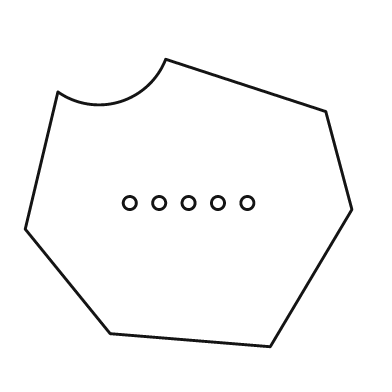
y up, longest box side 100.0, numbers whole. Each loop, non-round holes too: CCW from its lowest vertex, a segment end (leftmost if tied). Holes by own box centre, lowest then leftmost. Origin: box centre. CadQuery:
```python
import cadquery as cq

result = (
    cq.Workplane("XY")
    .moveTo(25.0, -44.0)
    .lineTo(50.0, -2.0)
    .lineTo(42.0, 28.0)
    .lineTo(-7.0, 44.0)
    .threePointArc((-21.0, 31.0), (-40.0, 34.0))
    .lineTo(-50.0, -8.0)
    .lineTo(-24.0, -40.0)
    .close()
    .moveTo(-18.0, 0.0)
    .circle(2.0)
    .moveTo(-9.0, 0.0)
    .circle(2.0)
    .moveTo(0.0, 0.0)
    .circle(2.0)
    .moveTo(9.0, 0.0)
    .circle(2.0)
    .moveTo(18.0, 0.0)
    .circle(2.0)
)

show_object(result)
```